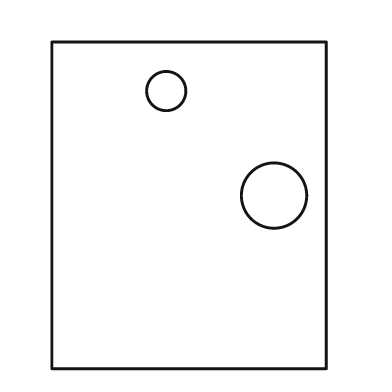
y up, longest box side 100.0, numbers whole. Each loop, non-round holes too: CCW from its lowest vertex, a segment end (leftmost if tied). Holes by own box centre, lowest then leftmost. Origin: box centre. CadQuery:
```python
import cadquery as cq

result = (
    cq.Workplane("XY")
    .moveTo(-42.0, -50.0)
    .lineTo(42.0, -50.0)
    .lineTo(42.0, 50.0)
    .lineTo(-42.0, 50.0)
    .close()
    .moveTo(26.0, 3.0)
    .circle(10.0)
    .moveTo(-7.0, 35.0)
    .circle(6.0)
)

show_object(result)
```